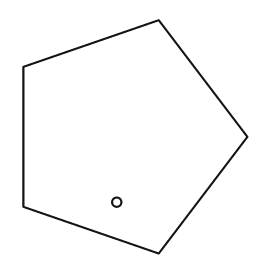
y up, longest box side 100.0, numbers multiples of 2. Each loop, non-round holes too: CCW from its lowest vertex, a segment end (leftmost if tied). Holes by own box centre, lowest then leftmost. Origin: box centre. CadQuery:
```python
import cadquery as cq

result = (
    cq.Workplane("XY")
    .moveTo(10.0, -50.0)
    .lineTo(48.0, 0.0)
    .lineTo(10.0, 50.0)
    .lineTo(-48.0, 30.0)
    .lineTo(-48.0, -30.0)
    .close()
    .moveTo(-8.0, -28.0)
    .circle(2.0)
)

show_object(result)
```